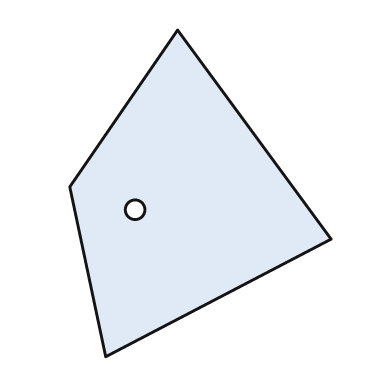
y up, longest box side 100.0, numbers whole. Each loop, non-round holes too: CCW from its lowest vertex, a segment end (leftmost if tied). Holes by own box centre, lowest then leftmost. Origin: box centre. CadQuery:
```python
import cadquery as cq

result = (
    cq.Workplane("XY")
    .moveTo(-29.0, -50.0)
    .lineTo(40.0, -14.0)
    .lineTo(-7.0, 50.0)
    .lineTo(-40.0, 2.0)
    .close()
    .moveTo(-20.0, -5.0)
    .circle(3.0)
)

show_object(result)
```